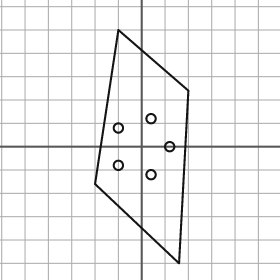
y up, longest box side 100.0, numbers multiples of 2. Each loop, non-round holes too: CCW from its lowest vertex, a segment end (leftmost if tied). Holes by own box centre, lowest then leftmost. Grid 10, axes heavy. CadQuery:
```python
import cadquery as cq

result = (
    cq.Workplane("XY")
    .moveTo(16.0, -50.0)
    .lineTo(20.0, 24.0)
    .lineTo(-10.0, 50.0)
    .lineTo(-20.0, -16.0)
    .close()
    .moveTo(4.0, -12.0)
    .circle(2.0)
    .moveTo(-10.0, -8.0)
    .circle(2.0)
    .moveTo(12.0, 0.0)
    .circle(2.0)
    .moveTo(-10.0, 8.0)
    .circle(2.0)
    .moveTo(4.0, 12.0)
    .circle(2.0)
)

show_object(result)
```